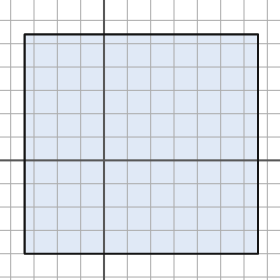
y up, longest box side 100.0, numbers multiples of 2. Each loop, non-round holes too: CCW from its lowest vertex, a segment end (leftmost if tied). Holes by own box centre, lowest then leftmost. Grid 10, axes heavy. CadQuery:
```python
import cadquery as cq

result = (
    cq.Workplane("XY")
    .moveTo(-34.0, -40.0)
    .lineTo(66.0, -40.0)
    .lineTo(66.0, 54.0)
    .lineTo(-34.0, 54.0)
    .close()
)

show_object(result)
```